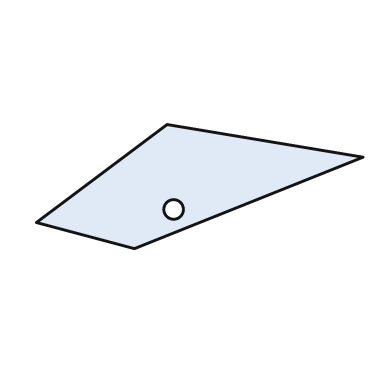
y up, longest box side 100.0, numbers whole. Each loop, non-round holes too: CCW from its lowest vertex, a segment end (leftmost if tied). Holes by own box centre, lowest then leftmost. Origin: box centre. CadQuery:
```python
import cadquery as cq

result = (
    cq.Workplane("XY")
    .moveTo(-20.0, -19.0)
    .lineTo(50.0, 9.0)
    .lineTo(-10.0, 19.0)
    .lineTo(-50.0, -11.0)
    .close()
    .moveTo(-8.0, -7.0)
    .circle(3.0)
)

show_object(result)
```